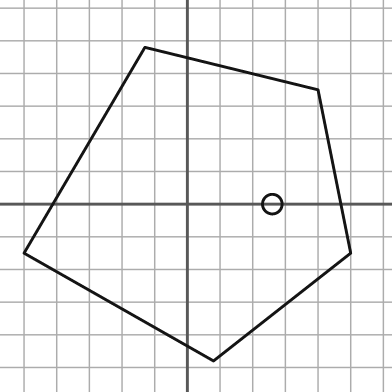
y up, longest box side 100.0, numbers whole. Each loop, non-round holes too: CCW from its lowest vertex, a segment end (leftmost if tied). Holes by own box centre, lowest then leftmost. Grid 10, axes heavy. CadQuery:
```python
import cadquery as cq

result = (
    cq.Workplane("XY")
    .moveTo(8.0, -48.0)
    .lineTo(50.0, -15.0)
    .lineTo(40.0, 35.0)
    .lineTo(-13.0, 48.0)
    .lineTo(-50.0, -15.0)
    .close()
    .moveTo(26.0, 0.0)
    .circle(3.0)
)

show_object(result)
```